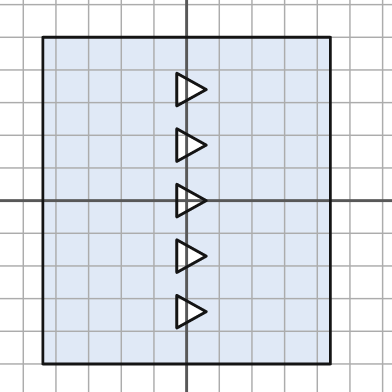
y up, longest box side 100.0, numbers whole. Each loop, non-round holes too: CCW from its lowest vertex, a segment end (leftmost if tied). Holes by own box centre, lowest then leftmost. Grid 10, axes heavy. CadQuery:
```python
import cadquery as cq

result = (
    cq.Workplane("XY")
    .moveTo(-44.0, -50.0)
    .lineTo(44.0, -50.0)
    .lineTo(44.0, 50.0)
    .lineTo(-44.0, 50.0)
    .close()
    .moveTo(-3.0, -39.0)
    .lineTo(6.0, -34.0)
    .lineTo(-3.0, -29.0)
    .close()
    .moveTo(-3.0, -22.0)
    .lineTo(6.0, -17.0)
    .lineTo(-3.0, -12.0)
    .close()
    .moveTo(-3.0, -5.0)
    .lineTo(6.0, 0.0)
    .lineTo(-3.0, 5.0)
    .close()
    .moveTo(-3.0, 12.0)
    .lineTo(6.0, 17.0)
    .lineTo(-3.0, 22.0)
    .close()
    .moveTo(-3.0, 29.0)
    .lineTo(6.0, 34.0)
    .lineTo(-3.0, 39.0)
    .close()
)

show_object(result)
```